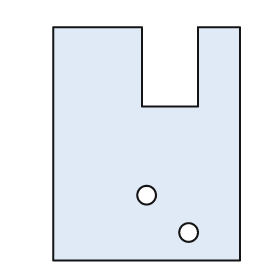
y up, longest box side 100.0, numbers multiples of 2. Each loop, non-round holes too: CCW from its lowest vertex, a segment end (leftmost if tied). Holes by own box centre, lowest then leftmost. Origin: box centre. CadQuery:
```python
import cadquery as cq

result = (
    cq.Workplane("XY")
    .moveTo(-40.0, -50.0)
    .lineTo(40.0, -50.0)
    .lineTo(40.0, 50.0)
    .lineTo(22.0, 50.0)
    .lineTo(22.0, 16.0)
    .lineTo(-2.0, 16.0)
    .lineTo(-2.0, 50.0)
    .lineTo(-40.0, 50.0)
    .close()
    .moveTo(18.0, -38.0)
    .circle(4.0)
    .moveTo(0.0, -22.0)
    .circle(4.0)
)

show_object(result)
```